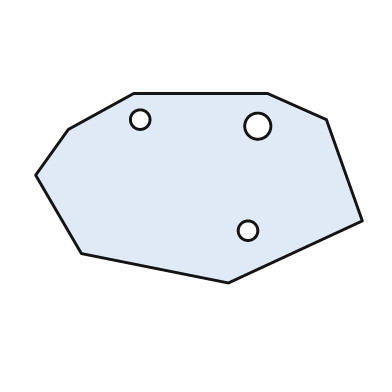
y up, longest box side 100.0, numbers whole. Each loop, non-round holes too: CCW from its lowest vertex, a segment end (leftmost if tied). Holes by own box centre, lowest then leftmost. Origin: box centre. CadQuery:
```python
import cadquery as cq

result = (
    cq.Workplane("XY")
    .moveTo(9.0, -29.0)
    .lineTo(50.0, -10.0)
    .lineTo(39.0, 21.0)
    .lineTo(21.0, 29.0)
    .lineTo(-20.0, 29.0)
    .lineTo(-40.0, 18.0)
    .lineTo(-50.0, 4.0)
    .lineTo(-36.0, -20.0)
    .close()
    .moveTo(15.0, -13.0)
    .circle(3.0)
    .moveTo(18.0, 19.0)
    .circle(4.0)
    .moveTo(-18.0, 21.0)
    .circle(3.0)
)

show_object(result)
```